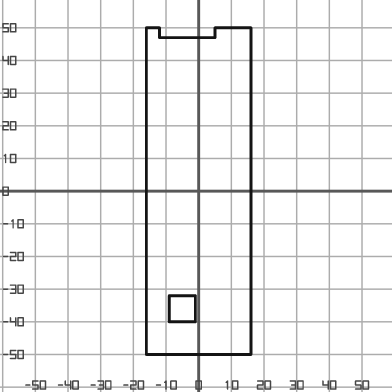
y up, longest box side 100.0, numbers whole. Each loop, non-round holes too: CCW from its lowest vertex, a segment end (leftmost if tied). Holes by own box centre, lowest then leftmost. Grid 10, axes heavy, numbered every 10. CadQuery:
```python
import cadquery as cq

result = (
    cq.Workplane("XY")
    .moveTo(-16.0, -50.0)
    .lineTo(16.0, -50.0)
    .lineTo(16.0, 50.0)
    .lineTo(5.0, 50.0)
    .lineTo(5.0, 47.0)
    .lineTo(-12.0, 47.0)
    .lineTo(-12.0, 50.0)
    .lineTo(-16.0, 50.0)
    .close()
    .moveTo(-9.0, -40.0)
    .lineTo(-1.0, -40.0)
    .lineTo(-1.0, -32.0)
    .lineTo(-9.0, -32.0)
    .close()
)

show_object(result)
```